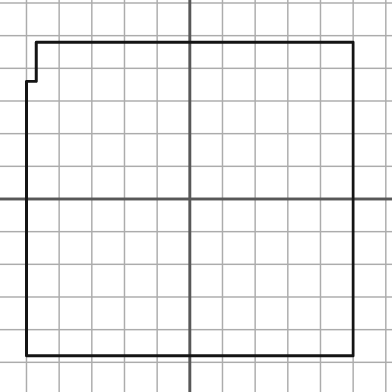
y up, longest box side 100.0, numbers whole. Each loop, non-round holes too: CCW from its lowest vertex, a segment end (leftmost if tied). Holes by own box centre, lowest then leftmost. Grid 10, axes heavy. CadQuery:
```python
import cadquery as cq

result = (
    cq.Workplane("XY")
    .moveTo(-50.0, -48.0)
    .lineTo(50.0, -48.0)
    .lineTo(50.0, 48.0)
    .lineTo(-47.0, 48.0)
    .lineTo(-47.0, 36.0)
    .lineTo(-50.0, 36.0)
    .close()
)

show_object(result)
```